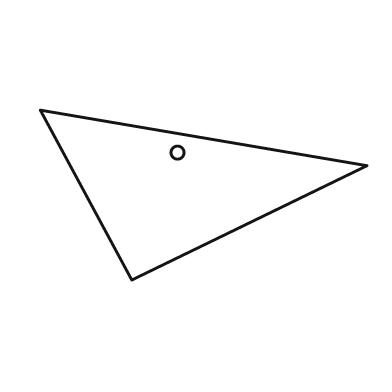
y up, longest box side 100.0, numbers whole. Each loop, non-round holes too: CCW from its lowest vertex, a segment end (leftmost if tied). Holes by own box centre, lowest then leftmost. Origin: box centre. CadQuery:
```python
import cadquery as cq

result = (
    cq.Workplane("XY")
    .moveTo(-22.0, -26.0)
    .lineTo(50.0, 9.0)
    .lineTo(-50.0, 26.0)
    .close()
    .moveTo(-8.0, 13.0)
    .circle(2.0)
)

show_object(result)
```